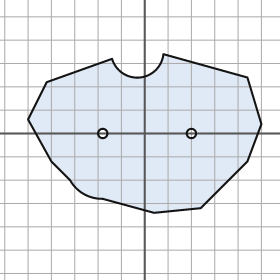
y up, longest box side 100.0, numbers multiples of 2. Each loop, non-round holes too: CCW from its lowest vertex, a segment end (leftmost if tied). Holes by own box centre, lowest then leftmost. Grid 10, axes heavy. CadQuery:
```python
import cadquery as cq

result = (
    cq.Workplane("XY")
    .moveTo(4.0, -34.0)
    .lineTo(24.0, -32.0)
    .lineTo(44.0, -12.0)
    .lineTo(50.0, 4.0)
    .lineTo(44.0, 24.0)
    .lineTo(8.0, 34.0)
    .threePointArc((-2.0, 24.0), (-14.0, 32.0))
    .lineTo(-42.0, 22.0)
    .lineTo(-50.0, 6.0)
    .lineTo(-40.0, -12.0)
    .lineTo(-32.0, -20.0)
    .threePointArc((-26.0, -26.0), (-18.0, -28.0))
    .close()
    .moveTo(-18.0, 0.0)
    .circle(2.0)
    .moveTo(20.0, 0.0)
    .circle(2.0)
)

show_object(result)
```